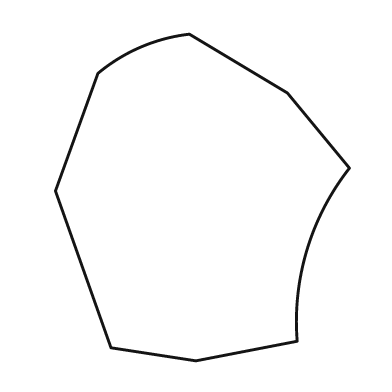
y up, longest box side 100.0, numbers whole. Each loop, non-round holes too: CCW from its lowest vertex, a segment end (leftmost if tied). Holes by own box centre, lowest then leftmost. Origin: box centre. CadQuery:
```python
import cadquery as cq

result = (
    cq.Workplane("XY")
    .moveTo(-2.0, -50.0)
    .lineTo(29.0, -44.0)
    .threePointArc((32.0, -16.0), (45.0, 9.0))
    .lineTo(26.0, 32.0)
    .lineTo(-4.0, 50.0)
    .threePointArc((-19.0, 46.0), (-32.0, 38.0))
    .lineTo(-45.0, 2.0)
    .lineTo(-28.0, -46.0)
    .close()
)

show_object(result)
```